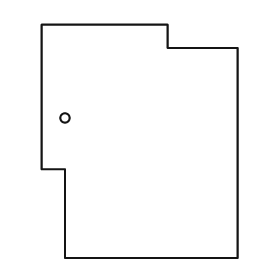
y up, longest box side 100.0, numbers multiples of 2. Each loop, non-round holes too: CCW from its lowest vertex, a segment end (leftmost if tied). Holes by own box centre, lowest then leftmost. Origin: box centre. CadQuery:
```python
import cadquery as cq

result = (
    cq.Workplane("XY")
    .moveTo(-32.0, -50.0)
    .lineTo(42.0, -50.0)
    .lineTo(42.0, 40.0)
    .lineTo(12.0, 40.0)
    .lineTo(12.0, 50.0)
    .lineTo(-42.0, 50.0)
    .lineTo(-42.0, -12.0)
    .lineTo(-32.0, -12.0)
    .close()
    .moveTo(-32.0, 10.0)
    .circle(2.0)
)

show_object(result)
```